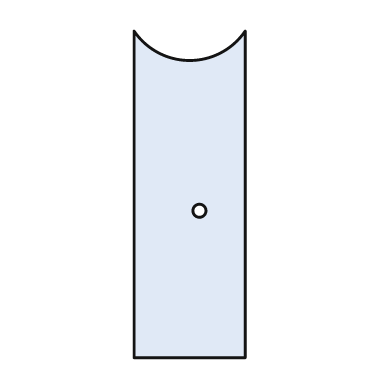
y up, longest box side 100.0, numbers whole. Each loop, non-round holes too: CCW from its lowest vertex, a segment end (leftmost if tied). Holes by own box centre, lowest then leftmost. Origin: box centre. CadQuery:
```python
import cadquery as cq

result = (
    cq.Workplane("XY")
    .moveTo(-17.0, -50.0)
    .lineTo(17.0, -50.0)
    .lineTo(17.0, 50.0)
    .threePointArc((0.0, 41.0), (-17.0, 50.0))
    .close()
    .moveTo(3.0, -5.0)
    .circle(2.0)
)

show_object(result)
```